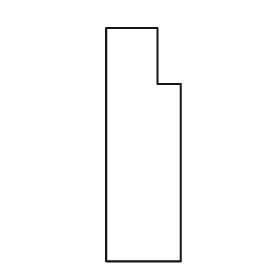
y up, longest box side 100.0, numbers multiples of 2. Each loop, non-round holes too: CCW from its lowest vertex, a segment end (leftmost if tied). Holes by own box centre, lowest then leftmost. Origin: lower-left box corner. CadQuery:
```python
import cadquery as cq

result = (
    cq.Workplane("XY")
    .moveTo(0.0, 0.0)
    .lineTo(32.0, 0.0)
    .lineTo(32.0, 76.0)
    .lineTo(22.0, 76.0)
    .lineTo(22.0, 100.0)
    .lineTo(0.0, 100.0)
    .close()
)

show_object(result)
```